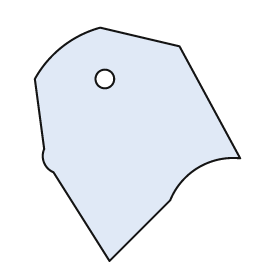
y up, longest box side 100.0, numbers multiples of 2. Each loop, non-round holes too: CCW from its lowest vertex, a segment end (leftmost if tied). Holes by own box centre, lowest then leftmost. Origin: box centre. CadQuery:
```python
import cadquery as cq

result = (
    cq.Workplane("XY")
    .moveTo(-12.0, -50.0)
    .lineTo(14.0, -24.0)
    .threePointArc((26.0, -10.0), (44.0, -6.0))
    .lineTo(18.0, 42.0)
    .lineTo(-16.0, 50.0)
    .threePointArc((-32.0, 42.0), (-44.0, 28.0))
    .lineTo(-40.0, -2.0)
    .threePointArc((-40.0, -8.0), (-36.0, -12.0))
    .close()
    .moveTo(-14.0, 28.0)
    .circle(4.0)
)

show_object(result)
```